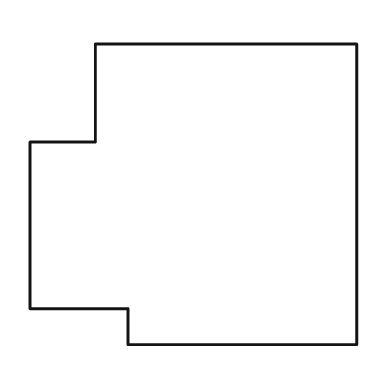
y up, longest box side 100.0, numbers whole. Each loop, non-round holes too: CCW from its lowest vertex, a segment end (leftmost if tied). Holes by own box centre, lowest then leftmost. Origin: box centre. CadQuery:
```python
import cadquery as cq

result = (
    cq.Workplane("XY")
    .moveTo(-20.0, -46.0)
    .lineTo(50.0, -46.0)
    .lineTo(50.0, 46.0)
    .lineTo(-30.0, 46.0)
    .lineTo(-30.0, 16.0)
    .lineTo(-50.0, 16.0)
    .lineTo(-50.0, -35.0)
    .lineTo(-20.0, -35.0)
    .close()
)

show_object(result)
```